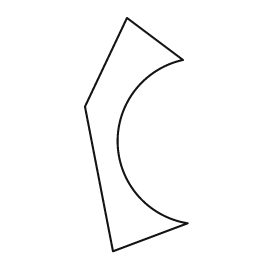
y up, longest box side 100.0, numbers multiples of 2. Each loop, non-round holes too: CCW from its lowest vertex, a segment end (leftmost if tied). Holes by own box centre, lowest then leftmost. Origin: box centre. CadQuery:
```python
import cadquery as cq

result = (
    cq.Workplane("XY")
    .moveTo(-10.0, -50.0)
    .lineTo(22.0, -38.0)
    .threePointArc((-8.0, -4.0), (20.0, 32.0))
    .lineTo(-4.0, 50.0)
    .lineTo(-22.0, 12.0)
    .close()
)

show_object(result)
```